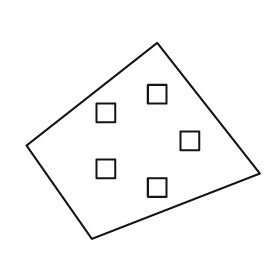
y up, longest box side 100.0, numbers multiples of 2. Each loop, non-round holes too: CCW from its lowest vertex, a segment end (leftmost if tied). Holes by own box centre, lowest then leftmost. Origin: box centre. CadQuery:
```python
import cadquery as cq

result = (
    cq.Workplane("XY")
    .moveTo(-22.0, -42.0)
    .lineTo(50.0, -14.0)
    .lineTo(6.0, 42.0)
    .lineTo(-50.0, -2.0)
    .close()
    .moveTo(2.0, -24.0)
    .lineTo(10.0, -24.0)
    .lineTo(10.0, -16.0)
    .lineTo(2.0, -16.0)
    .close()
    .moveTo(-20.0, -16.0)
    .lineTo(-12.0, -16.0)
    .lineTo(-12.0, -8.0)
    .lineTo(-20.0, -8.0)
    .close()
    .moveTo(16.0, -4.0)
    .lineTo(24.0, -4.0)
    .lineTo(24.0, 4.0)
    .lineTo(16.0, 4.0)
    .close()
    .moveTo(-20.0, 8.0)
    .lineTo(-12.0, 8.0)
    .lineTo(-12.0, 16.0)
    .lineTo(-20.0, 16.0)
    .close()
    .moveTo(2.0, 16.0)
    .lineTo(10.0, 16.0)
    .lineTo(10.0, 24.0)
    .lineTo(2.0, 24.0)
    .close()
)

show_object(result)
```